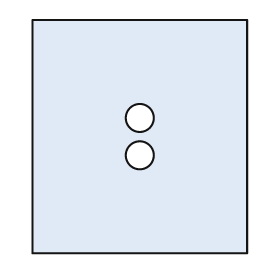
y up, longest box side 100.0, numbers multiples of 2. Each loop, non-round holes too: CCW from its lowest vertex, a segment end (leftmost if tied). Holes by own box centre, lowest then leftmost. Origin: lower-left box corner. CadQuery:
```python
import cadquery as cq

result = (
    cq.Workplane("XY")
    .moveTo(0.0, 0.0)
    .lineTo(92.0, 0.0)
    .lineTo(92.0, 100.0)
    .lineTo(0.0, 100.0)
    .close()
    .moveTo(46.0, 42.0)
    .circle(6.0)
    .moveTo(46.0, 58.0)
    .circle(6.0)
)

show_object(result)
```